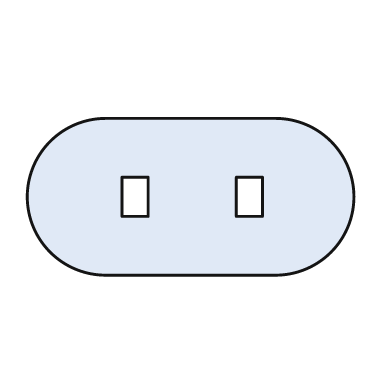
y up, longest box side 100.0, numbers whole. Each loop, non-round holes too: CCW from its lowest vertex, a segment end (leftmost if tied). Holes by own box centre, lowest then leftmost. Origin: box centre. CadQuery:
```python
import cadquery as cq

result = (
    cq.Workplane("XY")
    .moveTo(-26.0, -24.0)
    .lineTo(26.0, -24.0)
    .threePointArc((50.0, 0.0), (26.0, 24.0))
    .lineTo(-26.0, 24.0)
    .threePointArc((-50.0, 0.0), (-26.0, -24.0))
    .close()
    .moveTo(-21.0, -6.0)
    .lineTo(-13.0, -6.0)
    .lineTo(-13.0, 6.0)
    .lineTo(-21.0, 6.0)
    .close()
    .moveTo(14.0, -6.0)
    .lineTo(22.0, -6.0)
    .lineTo(22.0, 6.0)
    .lineTo(14.0, 6.0)
    .close()
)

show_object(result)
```